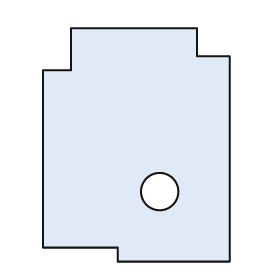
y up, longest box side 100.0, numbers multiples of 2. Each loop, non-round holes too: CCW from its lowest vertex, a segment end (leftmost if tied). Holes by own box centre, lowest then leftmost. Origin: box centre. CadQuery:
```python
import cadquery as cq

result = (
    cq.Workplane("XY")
    .moveTo(-8.0, -50.0)
    .lineTo(40.0, -50.0)
    .lineTo(40.0, 38.0)
    .lineTo(26.0, 38.0)
    .lineTo(26.0, 50.0)
    .lineTo(-28.0, 50.0)
    .lineTo(-28.0, 32.0)
    .lineTo(-40.0, 32.0)
    .lineTo(-40.0, -44.0)
    .lineTo(-8.0, -44.0)
    .close()
    .moveTo(10.0, -20.0)
    .circle(8.0)
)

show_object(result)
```